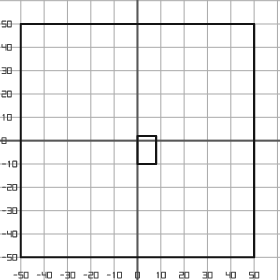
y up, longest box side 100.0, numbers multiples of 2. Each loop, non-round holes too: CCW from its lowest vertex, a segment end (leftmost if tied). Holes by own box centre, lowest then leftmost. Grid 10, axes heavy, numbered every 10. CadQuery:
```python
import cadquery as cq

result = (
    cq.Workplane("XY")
    .moveTo(-50.0, -50.0)
    .lineTo(50.0, -50.0)
    .lineTo(50.0, 50.0)
    .lineTo(-50.0, 50.0)
    .close()
    .moveTo(0.0, -10.0)
    .lineTo(8.0, -10.0)
    .lineTo(8.0, 2.0)
    .lineTo(0.0, 2.0)
    .close()
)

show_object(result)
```